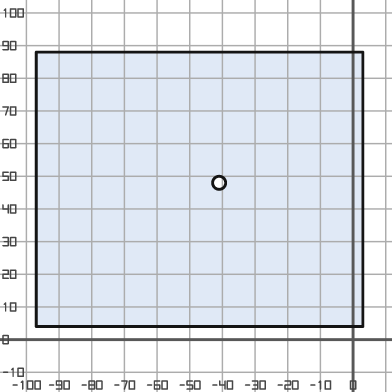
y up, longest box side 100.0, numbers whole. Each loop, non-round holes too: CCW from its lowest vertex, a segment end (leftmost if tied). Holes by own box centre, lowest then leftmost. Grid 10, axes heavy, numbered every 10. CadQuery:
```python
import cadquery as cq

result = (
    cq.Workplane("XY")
    .moveTo(-97.0, 4.0)
    .lineTo(3.0, 4.0)
    .lineTo(3.0, 88.0)
    .lineTo(-97.0, 88.0)
    .close()
    .moveTo(-41.0, 48.0)
    .circle(2.0)
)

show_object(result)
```